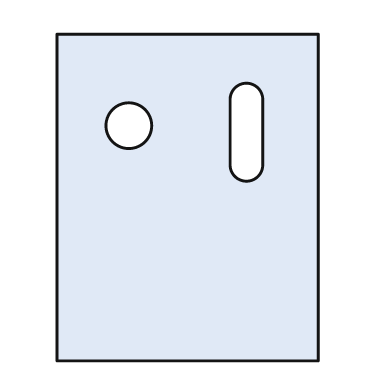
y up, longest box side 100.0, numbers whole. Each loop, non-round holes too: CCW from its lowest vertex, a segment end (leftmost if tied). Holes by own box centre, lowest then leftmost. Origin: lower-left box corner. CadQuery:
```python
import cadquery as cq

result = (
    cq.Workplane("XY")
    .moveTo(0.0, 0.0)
    .lineTo(80.0, 0.0)
    .lineTo(80.0, 100.0)
    .lineTo(0.0, 100.0)
    .close()
    .moveTo(53.0, 60.0)
    .threePointArc((58.0, 55.0), (63.0, 60.0))
    .lineTo(63.0, 80.0)
    .threePointArc((58.0, 85.0), (53.0, 80.0))
    .close()
    .moveTo(22.0, 72.0)
    .circle(7.0)
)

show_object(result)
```